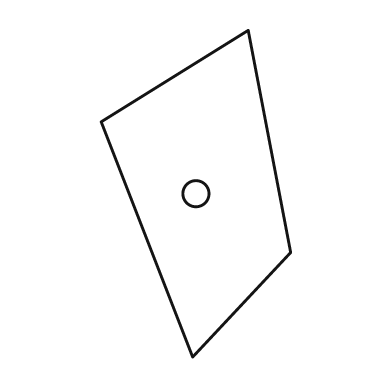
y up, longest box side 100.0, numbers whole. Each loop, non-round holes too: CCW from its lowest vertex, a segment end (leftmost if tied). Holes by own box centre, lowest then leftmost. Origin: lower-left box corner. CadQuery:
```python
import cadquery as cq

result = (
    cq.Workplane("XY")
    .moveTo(28.0, 0.0)
    .lineTo(58.0, 32.0)
    .lineTo(45.0, 100.0)
    .lineTo(0.0, 72.0)
    .close()
    .moveTo(29.0, 50.0)
    .circle(4.0)
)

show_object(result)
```